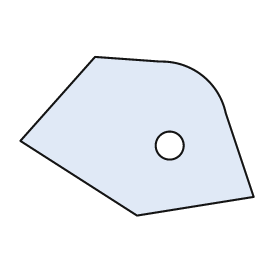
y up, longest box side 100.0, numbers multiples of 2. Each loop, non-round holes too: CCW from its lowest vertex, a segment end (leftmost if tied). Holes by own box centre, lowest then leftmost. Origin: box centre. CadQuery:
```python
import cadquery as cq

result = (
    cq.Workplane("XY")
    .moveTo(0.0, -34.0)
    .lineTo(50.0, -26.0)
    .lineTo(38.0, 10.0)
    .threePointArc((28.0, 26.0), (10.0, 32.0))
    .lineTo(-18.0, 34.0)
    .lineTo(-50.0, -2.0)
    .close()
    .moveTo(14.0, -4.0)
    .circle(6.0)
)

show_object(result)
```